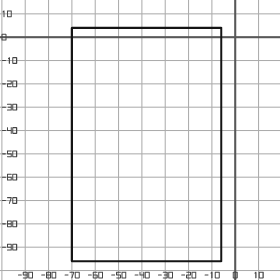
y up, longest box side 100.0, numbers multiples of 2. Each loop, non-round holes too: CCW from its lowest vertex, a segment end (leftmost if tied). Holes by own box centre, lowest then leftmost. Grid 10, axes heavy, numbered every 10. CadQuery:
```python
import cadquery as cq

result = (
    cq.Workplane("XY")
    .moveTo(-70.0, -96.0)
    .lineTo(-6.0, -96.0)
    .lineTo(-6.0, 4.0)
    .lineTo(-70.0, 4.0)
    .close()
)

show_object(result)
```